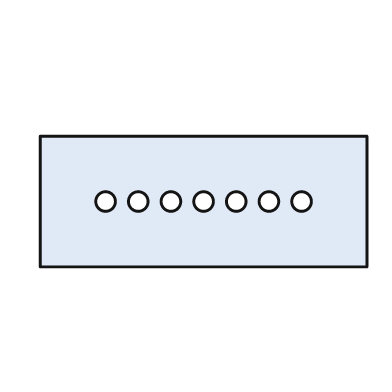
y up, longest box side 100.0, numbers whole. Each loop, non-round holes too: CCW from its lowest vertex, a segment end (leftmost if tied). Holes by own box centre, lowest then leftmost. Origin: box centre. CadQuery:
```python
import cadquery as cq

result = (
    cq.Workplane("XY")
    .moveTo(-50.0, -20.0)
    .lineTo(50.0, -20.0)
    .lineTo(50.0, 20.0)
    .lineTo(-50.0, 20.0)
    .close()
    .moveTo(-30.0, 0.0)
    .circle(3.0)
    .moveTo(-20.0, 0.0)
    .circle(3.0)
    .moveTo(-10.0, 0.0)
    .circle(3.0)
    .moveTo(0.0, 0.0)
    .circle(3.0)
    .moveTo(10.0, 0.0)
    .circle(3.0)
    .moveTo(20.0, 0.0)
    .circle(3.0)
    .moveTo(30.0, 0.0)
    .circle(3.0)
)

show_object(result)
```